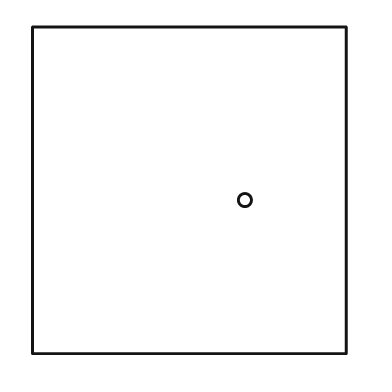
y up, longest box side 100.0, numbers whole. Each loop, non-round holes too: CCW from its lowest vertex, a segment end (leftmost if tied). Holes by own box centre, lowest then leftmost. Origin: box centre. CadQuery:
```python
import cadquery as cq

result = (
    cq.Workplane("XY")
    .moveTo(-48.0, -50.0)
    .lineTo(48.0, -50.0)
    .lineTo(48.0, 50.0)
    .lineTo(-48.0, 50.0)
    .close()
    .moveTo(17.0, -3.0)
    .circle(2.0)
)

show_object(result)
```